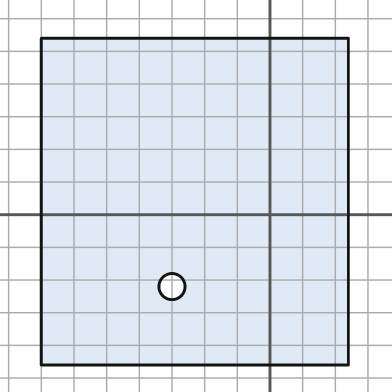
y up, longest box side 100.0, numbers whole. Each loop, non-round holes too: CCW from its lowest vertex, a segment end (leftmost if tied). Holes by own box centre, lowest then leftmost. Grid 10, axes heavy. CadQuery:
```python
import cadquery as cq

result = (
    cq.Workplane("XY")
    .moveTo(-70.0, -46.0)
    .lineTo(24.0, -46.0)
    .lineTo(24.0, 54.0)
    .lineTo(-70.0, 54.0)
    .close()
    .moveTo(-30.0, -22.0)
    .circle(4.0)
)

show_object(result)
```